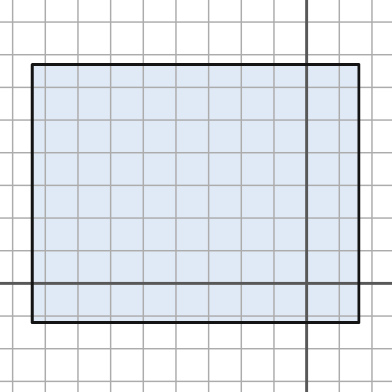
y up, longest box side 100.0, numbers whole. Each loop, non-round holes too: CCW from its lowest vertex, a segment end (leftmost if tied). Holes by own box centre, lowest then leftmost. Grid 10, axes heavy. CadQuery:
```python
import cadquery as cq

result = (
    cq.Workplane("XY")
    .moveTo(-84.0, -12.0)
    .lineTo(16.0, -12.0)
    .lineTo(16.0, 67.0)
    .lineTo(-84.0, 67.0)
    .close()
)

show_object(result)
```